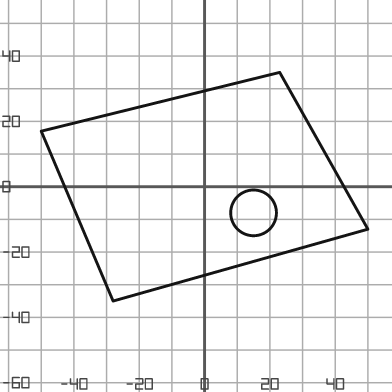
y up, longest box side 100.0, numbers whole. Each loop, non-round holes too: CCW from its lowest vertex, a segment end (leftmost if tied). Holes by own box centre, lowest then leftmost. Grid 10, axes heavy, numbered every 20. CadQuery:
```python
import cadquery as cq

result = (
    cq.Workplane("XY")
    .moveTo(-28.0, -35.0)
    .lineTo(50.0, -13.0)
    .lineTo(23.0, 35.0)
    .lineTo(-50.0, 17.0)
    .close()
    .moveTo(15.0, -8.0)
    .circle(7.0)
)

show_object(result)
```